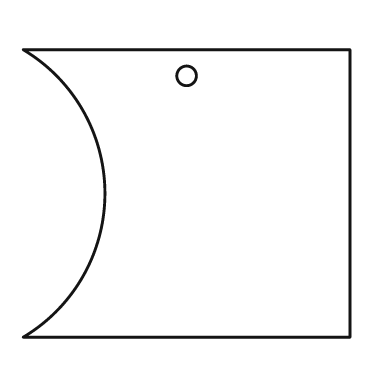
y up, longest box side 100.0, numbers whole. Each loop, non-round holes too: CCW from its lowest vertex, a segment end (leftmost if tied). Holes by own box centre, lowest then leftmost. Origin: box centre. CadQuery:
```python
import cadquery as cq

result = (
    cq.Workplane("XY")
    .moveTo(-50.0, -44.0)
    .lineTo(50.0, -44.0)
    .lineTo(50.0, 44.0)
    .lineTo(-50.0, 44.0)
    .threePointArc((-25.0, 0.0), (-50.0, -44.0))
    .close()
    .moveTo(0.0, 36.0)
    .circle(3.0)
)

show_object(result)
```